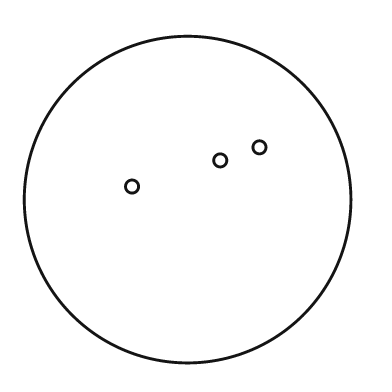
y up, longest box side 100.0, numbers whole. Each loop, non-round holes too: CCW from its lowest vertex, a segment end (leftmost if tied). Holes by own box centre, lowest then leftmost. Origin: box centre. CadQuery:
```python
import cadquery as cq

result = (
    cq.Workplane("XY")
    .moveTo(0.0, 0.0)
    .circle(50.0)
    .moveTo(-17.0, 4.0)
    .circle(2.0)
    .moveTo(10.0, 12.0)
    .circle(2.0)
    .moveTo(22.0, 16.0)
    .circle(2.0)
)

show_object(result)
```